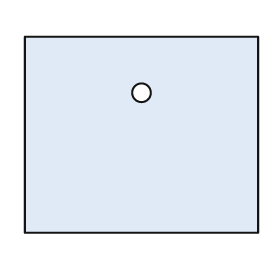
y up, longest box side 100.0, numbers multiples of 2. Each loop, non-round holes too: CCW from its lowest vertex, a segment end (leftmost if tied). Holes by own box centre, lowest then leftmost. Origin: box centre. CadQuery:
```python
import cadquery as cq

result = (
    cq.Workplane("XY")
    .moveTo(-50.0, -42.0)
    .lineTo(50.0, -42.0)
    .lineTo(50.0, 42.0)
    .lineTo(-50.0, 42.0)
    .close()
    .moveTo(0.0, 18.0)
    .circle(4.0)
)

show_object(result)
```